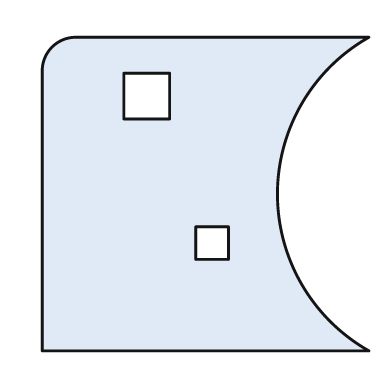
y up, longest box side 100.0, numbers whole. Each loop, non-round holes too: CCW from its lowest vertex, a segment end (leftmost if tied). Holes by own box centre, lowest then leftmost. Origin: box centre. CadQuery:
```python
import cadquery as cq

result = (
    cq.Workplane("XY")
    .moveTo(-50.0, -48.0)
    .lineTo(50.0, -48.0)
    .threePointArc((22.0, 0.0), (50.0, 48.0))
    .lineTo(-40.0, 48.0)
    .threePointArc((-47.0, 45.0), (-50.0, 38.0))
    .close()
    .moveTo(-3.0, -20.0)
    .lineTo(7.0, -20.0)
    .lineTo(7.0, -10.0)
    .lineTo(-3.0, -10.0)
    .close()
    .moveTo(-25.0, 23.0)
    .lineTo(-11.0, 23.0)
    .lineTo(-11.0, 37.0)
    .lineTo(-25.0, 37.0)
    .close()
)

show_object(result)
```